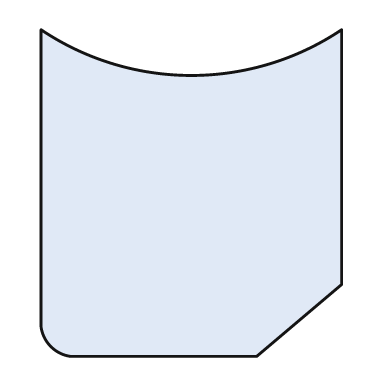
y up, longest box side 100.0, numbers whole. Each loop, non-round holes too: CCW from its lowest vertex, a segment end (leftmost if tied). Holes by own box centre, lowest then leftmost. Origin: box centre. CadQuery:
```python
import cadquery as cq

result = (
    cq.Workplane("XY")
    .moveTo(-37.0, -50.0)
    .lineTo(20.0, -50.0)
    .lineTo(46.0, -28.0)
    .lineTo(46.0, 50.0)
    .threePointArc((0.0, 36.0), (-46.0, 50.0))
    .lineTo(-46.0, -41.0)
    .threePointArc((-43.0, -47.0), (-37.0, -50.0))
    .close()
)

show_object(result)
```